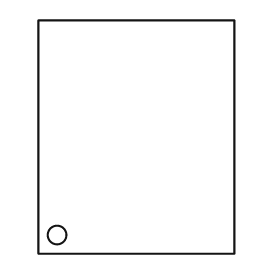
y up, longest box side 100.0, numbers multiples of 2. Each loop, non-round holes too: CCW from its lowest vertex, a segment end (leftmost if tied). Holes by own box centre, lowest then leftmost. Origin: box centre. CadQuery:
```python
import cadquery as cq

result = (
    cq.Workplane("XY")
    .moveTo(-42.0, -50.0)
    .lineTo(42.0, -50.0)
    .lineTo(42.0, 50.0)
    .lineTo(-42.0, 50.0)
    .close()
    .moveTo(-34.0, -42.0)
    .circle(4.0)
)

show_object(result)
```